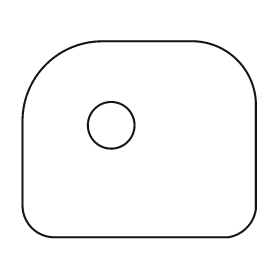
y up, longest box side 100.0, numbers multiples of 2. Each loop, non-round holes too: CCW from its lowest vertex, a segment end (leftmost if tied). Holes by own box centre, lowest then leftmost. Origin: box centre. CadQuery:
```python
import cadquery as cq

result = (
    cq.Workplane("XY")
    .moveTo(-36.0, -42.0)
    .lineTo(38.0, -42.0)
    .threePointArc((46.0, -38.0), (50.0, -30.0))
    .lineTo(50.0, 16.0)
    .threePointArc((42.0, 34.0), (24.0, 42.0))
    .lineTo(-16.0, 42.0)
    .threePointArc((-40.0, 32.0), (-50.0, 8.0))
    .lineTo(-50.0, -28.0)
    .threePointArc((-46.0, -38.0), (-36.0, -42.0))
    .close()
    .moveTo(-12.0, 6.0)
    .circle(10.0)
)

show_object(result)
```